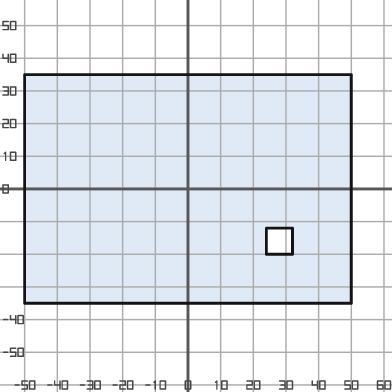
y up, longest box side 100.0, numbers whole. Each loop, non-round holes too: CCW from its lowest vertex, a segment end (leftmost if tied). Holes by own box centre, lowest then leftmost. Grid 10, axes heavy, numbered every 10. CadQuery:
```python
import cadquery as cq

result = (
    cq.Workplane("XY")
    .moveTo(-50.0, -35.0)
    .lineTo(50.0, -35.0)
    .lineTo(50.0, 35.0)
    .lineTo(-50.0, 35.0)
    .close()
    .moveTo(24.0, -20.0)
    .lineTo(32.0, -20.0)
    .lineTo(32.0, -12.0)
    .lineTo(24.0, -12.0)
    .close()
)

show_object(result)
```